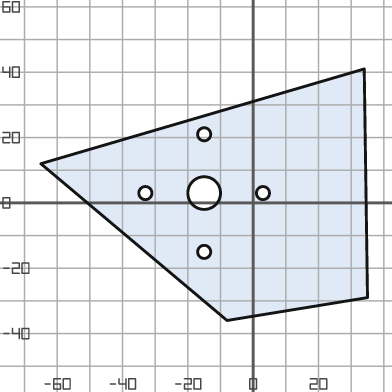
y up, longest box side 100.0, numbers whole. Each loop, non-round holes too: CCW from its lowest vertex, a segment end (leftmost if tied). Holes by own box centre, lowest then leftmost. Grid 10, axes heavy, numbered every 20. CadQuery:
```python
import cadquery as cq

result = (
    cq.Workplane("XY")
    .moveTo(-8.0, -36.0)
    .lineTo(35.0, -29.0)
    .lineTo(34.0, 41.0)
    .lineTo(-65.0, 12.0)
    .close()
    .moveTo(-15.0, -15.0)
    .circle(2.0)
    .moveTo(-33.0, 3.0)
    .circle(2.0)
    .moveTo(-15.0, 3.0)
    .circle(5.0)
    .moveTo(3.0, 3.0)
    .circle(2.0)
    .moveTo(-15.0, 21.0)
    .circle(2.0)
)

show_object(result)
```